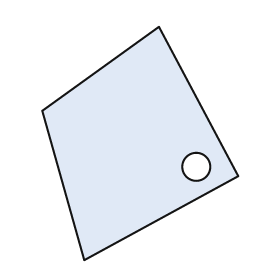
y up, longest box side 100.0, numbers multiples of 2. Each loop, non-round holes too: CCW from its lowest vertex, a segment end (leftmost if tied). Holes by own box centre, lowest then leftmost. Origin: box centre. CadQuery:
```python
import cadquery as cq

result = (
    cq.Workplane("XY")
    .moveTo(-24.0, -50.0)
    .lineTo(42.0, -14.0)
    .lineTo(8.0, 50.0)
    .lineTo(-42.0, 14.0)
    .close()
    .moveTo(24.0, -10.0)
    .circle(6.0)
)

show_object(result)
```